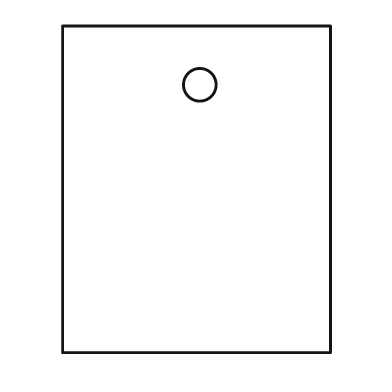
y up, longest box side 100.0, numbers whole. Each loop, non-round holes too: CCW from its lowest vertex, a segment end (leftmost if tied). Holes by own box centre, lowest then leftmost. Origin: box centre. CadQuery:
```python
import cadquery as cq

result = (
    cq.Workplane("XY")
    .moveTo(-41.0, -50.0)
    .lineTo(41.0, -50.0)
    .lineTo(41.0, 50.0)
    .lineTo(-41.0, 50.0)
    .close()
    .moveTo(1.0, 32.0)
    .circle(5.0)
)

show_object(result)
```